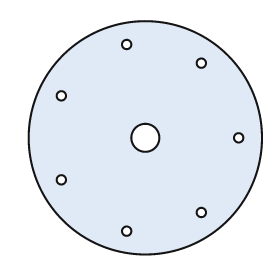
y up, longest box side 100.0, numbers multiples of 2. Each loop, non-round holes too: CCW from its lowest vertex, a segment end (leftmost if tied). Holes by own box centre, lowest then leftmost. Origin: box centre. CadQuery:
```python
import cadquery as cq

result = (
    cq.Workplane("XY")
    .moveTo(0.0, 0.0)
    .circle(50.0)
    .moveTo(-8.0, -40.0)
    .circle(2.0)
    .moveTo(24.0, -32.0)
    .circle(2.0)
    .moveTo(-36.0, -18.0)
    .circle(2.0)
    .moveTo(0.0, 0.0)
    .circle(6.0)
    .moveTo(40.0, 0.0)
    .circle(2.0)
    .moveTo(-36.0, 18.0)
    .circle(2.0)
    .moveTo(24.0, 32.0)
    .circle(2.0)
    .moveTo(-8.0, 40.0)
    .circle(2.0)
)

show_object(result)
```